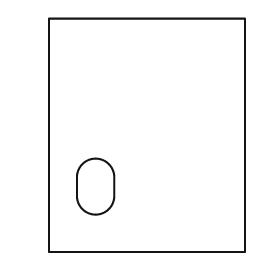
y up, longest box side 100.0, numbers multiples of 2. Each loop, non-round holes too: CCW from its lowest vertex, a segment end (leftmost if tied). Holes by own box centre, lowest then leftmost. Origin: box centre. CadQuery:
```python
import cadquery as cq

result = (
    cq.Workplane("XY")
    .moveTo(-42.0, -50.0)
    .lineTo(42.0, -50.0)
    .lineTo(42.0, 50.0)
    .lineTo(-42.0, 50.0)
    .close()
    .moveTo(-30.0, -26.0)
    .threePointArc((-22.0, -34.0), (-14.0, -26.0))
    .lineTo(-14.0, -18.0)
    .threePointArc((-22.0, -10.0), (-30.0, -18.0))
    .close()
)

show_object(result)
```